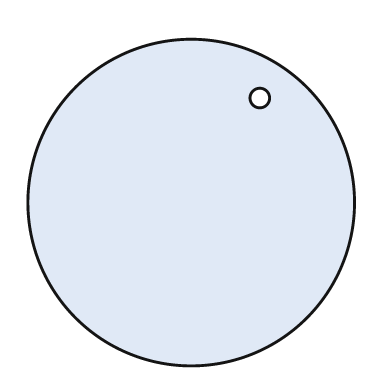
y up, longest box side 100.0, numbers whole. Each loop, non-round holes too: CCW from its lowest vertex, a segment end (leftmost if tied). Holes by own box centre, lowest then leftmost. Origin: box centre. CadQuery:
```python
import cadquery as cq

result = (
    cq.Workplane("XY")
    .moveTo(0.0, 0.0)
    .circle(50.0)
    .moveTo(21.0, 32.0)
    .circle(3.0)
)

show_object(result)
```